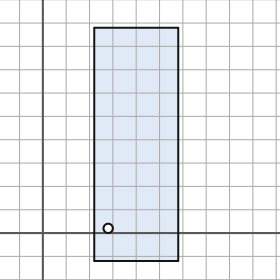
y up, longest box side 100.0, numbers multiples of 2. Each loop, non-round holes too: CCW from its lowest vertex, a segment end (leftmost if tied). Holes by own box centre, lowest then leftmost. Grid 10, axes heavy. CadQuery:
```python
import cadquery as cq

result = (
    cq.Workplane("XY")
    .moveTo(22.0, -12.0)
    .lineTo(58.0, -12.0)
    .lineTo(58.0, 88.0)
    .lineTo(22.0, 88.0)
    .close()
    .moveTo(28.0, 2.0)
    .circle(2.0)
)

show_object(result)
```